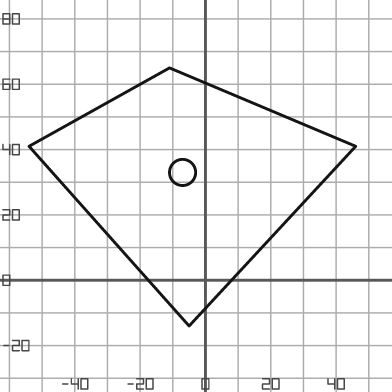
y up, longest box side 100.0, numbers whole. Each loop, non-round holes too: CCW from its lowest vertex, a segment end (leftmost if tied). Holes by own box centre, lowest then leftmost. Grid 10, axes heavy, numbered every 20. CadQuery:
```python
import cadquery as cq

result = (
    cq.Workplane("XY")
    .moveTo(-5.0, -14.0)
    .lineTo(46.0, 41.0)
    .lineTo(-11.0, 65.0)
    .lineTo(-54.0, 41.0)
    .close()
    .moveTo(-7.0, 33.0)
    .circle(4.0)
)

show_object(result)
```